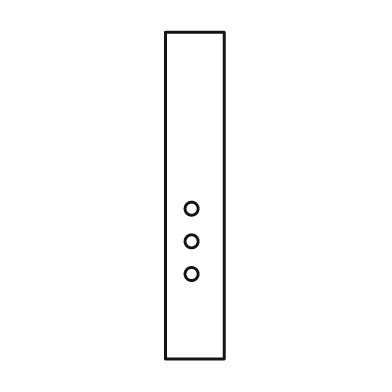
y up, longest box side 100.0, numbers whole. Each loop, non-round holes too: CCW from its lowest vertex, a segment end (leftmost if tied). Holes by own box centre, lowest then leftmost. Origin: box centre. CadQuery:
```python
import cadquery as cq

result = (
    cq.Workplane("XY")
    .moveTo(-9.0, -50.0)
    .lineTo(9.0, -50.0)
    .lineTo(9.0, 50.0)
    .lineTo(-9.0, 50.0)
    .close()
    .moveTo(-1.0, -24.0)
    .circle(2.0)
    .moveTo(-1.0, -14.0)
    .circle(2.0)
    .moveTo(-1.0, -4.0)
    .circle(2.0)
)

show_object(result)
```